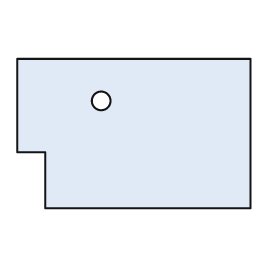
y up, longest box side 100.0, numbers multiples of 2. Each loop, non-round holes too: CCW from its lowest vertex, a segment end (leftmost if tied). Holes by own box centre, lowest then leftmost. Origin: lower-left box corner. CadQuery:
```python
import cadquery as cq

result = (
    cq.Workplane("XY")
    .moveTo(12.0, 0.0)
    .lineTo(100.0, 0.0)
    .lineTo(100.0, 64.0)
    .lineTo(0.0, 64.0)
    .lineTo(0.0, 24.0)
    .lineTo(12.0, 24.0)
    .close()
    .moveTo(36.0, 46.0)
    .circle(4.0)
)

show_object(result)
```